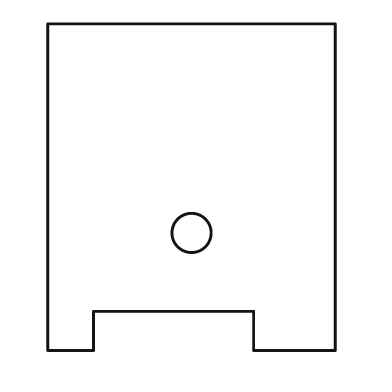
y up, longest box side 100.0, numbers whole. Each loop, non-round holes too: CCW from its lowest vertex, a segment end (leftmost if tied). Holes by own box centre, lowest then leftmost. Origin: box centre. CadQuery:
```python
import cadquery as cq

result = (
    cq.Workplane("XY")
    .moveTo(-44.0, -50.0)
    .lineTo(-30.0, -50.0)
    .lineTo(-30.0, -38.0)
    .lineTo(19.0, -38.0)
    .lineTo(19.0, -50.0)
    .lineTo(44.0, -50.0)
    .lineTo(44.0, 50.0)
    .lineTo(-44.0, 50.0)
    .close()
    .moveTo(0.0, -14.0)
    .circle(6.0)
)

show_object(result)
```